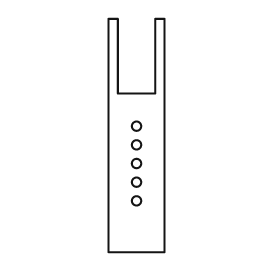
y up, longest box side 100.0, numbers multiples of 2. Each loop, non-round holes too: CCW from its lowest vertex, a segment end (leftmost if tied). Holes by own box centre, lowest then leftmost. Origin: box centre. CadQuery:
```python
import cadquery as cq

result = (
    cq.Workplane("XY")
    .moveTo(-12.0, -50.0)
    .lineTo(12.0, -50.0)
    .lineTo(12.0, 50.0)
    .lineTo(8.0, 50.0)
    .lineTo(8.0, 18.0)
    .lineTo(-8.0, 18.0)
    .lineTo(-8.0, 50.0)
    .lineTo(-12.0, 50.0)
    .close()
    .moveTo(0.0, -28.0)
    .circle(2.0)
    .moveTo(0.0, -20.0)
    .circle(2.0)
    .moveTo(0.0, -12.0)
    .circle(2.0)
    .moveTo(0.0, -4.0)
    .circle(2.0)
    .moveTo(0.0, 4.0)
    .circle(2.0)
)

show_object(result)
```